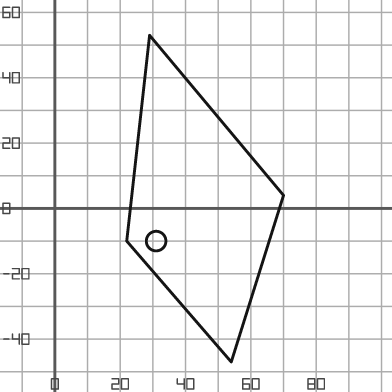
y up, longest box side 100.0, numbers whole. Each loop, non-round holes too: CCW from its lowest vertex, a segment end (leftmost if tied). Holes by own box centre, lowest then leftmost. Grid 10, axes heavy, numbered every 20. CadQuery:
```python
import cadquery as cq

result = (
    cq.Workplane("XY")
    .moveTo(54.0, -47.0)
    .lineTo(70.0, 4.0)
    .lineTo(29.0, 53.0)
    .lineTo(22.0, -10.0)
    .close()
    .moveTo(31.0, -10.0)
    .circle(3.0)
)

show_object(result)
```